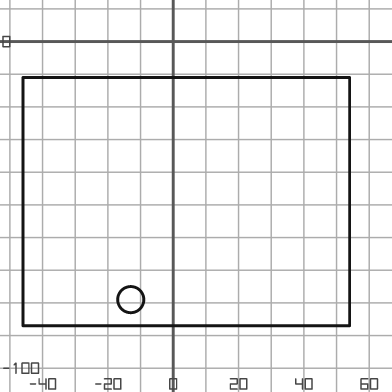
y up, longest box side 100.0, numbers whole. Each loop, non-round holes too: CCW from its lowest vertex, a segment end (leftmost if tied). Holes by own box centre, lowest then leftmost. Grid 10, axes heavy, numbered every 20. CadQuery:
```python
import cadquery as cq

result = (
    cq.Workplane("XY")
    .moveTo(-46.0, -87.0)
    .lineTo(54.0, -87.0)
    .lineTo(54.0, -11.0)
    .lineTo(-46.0, -11.0)
    .close()
    .moveTo(-13.0, -79.0)
    .circle(4.0)
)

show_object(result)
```